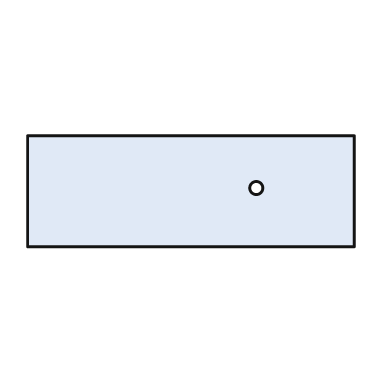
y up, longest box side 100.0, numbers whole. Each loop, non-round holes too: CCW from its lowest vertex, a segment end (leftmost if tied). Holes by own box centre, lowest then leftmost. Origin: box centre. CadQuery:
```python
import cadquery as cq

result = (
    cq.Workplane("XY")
    .moveTo(-50.0, -17.0)
    .lineTo(50.0, -17.0)
    .lineTo(50.0, 17.0)
    .lineTo(-50.0, 17.0)
    .close()
    .moveTo(20.0, 1.0)
    .circle(2.0)
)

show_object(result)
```